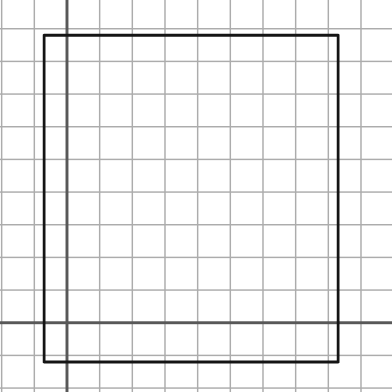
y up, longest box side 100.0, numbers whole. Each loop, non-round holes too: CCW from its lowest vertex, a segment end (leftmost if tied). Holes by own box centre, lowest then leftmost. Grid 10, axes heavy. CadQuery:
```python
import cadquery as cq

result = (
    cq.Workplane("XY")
    .moveTo(-7.0, -12.0)
    .lineTo(83.0, -12.0)
    .lineTo(83.0, 88.0)
    .lineTo(-7.0, 88.0)
    .close()
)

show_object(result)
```